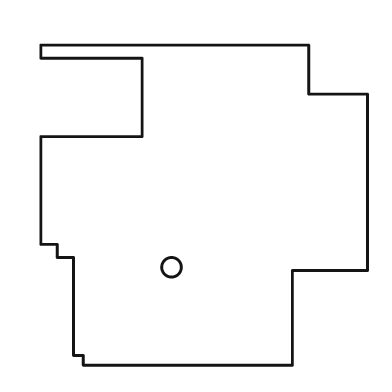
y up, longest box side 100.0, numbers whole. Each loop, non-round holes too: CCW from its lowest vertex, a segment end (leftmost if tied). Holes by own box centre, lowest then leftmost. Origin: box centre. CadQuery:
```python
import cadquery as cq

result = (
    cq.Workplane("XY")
    .moveTo(-37.0, -49.0)
    .lineTo(27.0, -49.0)
    .lineTo(27.0, -20.0)
    .lineTo(50.0, -20.0)
    .lineTo(50.0, 34.0)
    .lineTo(32.0, 34.0)
    .lineTo(32.0, 49.0)
    .lineTo(-50.0, 49.0)
    .lineTo(-50.0, 45.0)
    .lineTo(-19.0, 45.0)
    .lineTo(-19.0, 21.0)
    .lineTo(-50.0, 21.0)
    .lineTo(-50.0, -12.0)
    .lineTo(-45.0, -12.0)
    .lineTo(-45.0, -16.0)
    .lineTo(-40.0, -16.0)
    .lineTo(-40.0, -46.0)
    .lineTo(-37.0, -46.0)
    .close()
    .moveTo(-10.0, -19.0)
    .circle(3.0)
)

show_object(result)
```